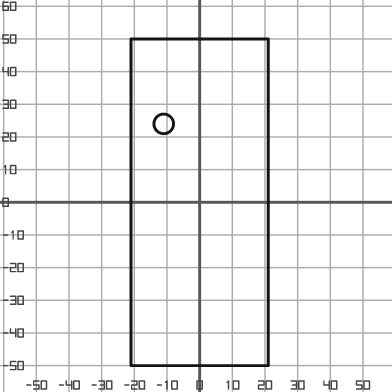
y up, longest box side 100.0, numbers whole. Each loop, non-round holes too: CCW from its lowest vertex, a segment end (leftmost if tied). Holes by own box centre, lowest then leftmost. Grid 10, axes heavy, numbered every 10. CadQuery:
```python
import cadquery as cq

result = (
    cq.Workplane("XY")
    .moveTo(-21.0, -50.0)
    .lineTo(21.0, -50.0)
    .lineTo(21.0, 50.0)
    .lineTo(-21.0, 50.0)
    .close()
    .moveTo(-11.0, 24.0)
    .circle(3.0)
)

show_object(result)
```